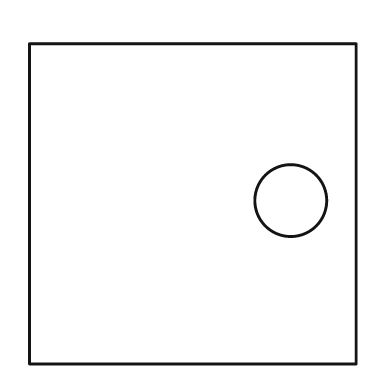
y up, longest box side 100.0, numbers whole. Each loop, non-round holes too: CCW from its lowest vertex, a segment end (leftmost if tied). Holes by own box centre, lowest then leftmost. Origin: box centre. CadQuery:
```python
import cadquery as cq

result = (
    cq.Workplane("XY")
    .moveTo(-50.0, -49.0)
    .lineTo(50.0, -49.0)
    .lineTo(50.0, 49.0)
    .lineTo(-50.0, 49.0)
    .close()
    .moveTo(30.0, 1.0)
    .circle(11.0)
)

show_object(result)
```